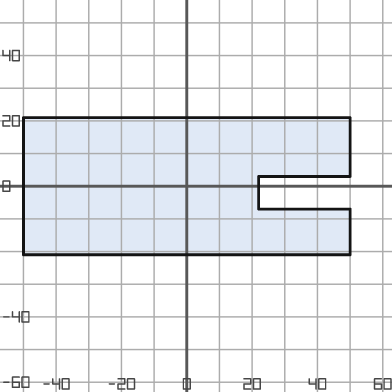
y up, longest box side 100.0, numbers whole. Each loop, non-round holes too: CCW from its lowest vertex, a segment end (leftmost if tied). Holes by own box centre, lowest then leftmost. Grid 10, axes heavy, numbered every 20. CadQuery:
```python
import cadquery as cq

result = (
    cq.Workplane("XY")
    .moveTo(-50.0, -21.0)
    .lineTo(50.0, -21.0)
    .lineTo(50.0, -7.0)
    .lineTo(22.0, -7.0)
    .lineTo(22.0, 3.0)
    .lineTo(50.0, 3.0)
    .lineTo(50.0, 21.0)
    .lineTo(-50.0, 21.0)
    .close()
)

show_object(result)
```